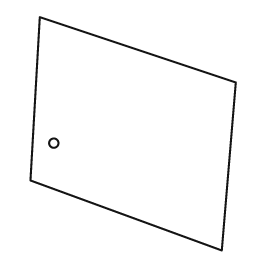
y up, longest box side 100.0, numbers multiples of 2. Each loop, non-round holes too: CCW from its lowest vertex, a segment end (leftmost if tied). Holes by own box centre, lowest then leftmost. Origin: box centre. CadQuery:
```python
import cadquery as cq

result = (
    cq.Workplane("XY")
    .moveTo(38.0, -50.0)
    .lineTo(44.0, 22.0)
    .lineTo(-40.0, 50.0)
    .lineTo(-44.0, -20.0)
    .close()
    .moveTo(-34.0, -4.0)
    .circle(2.0)
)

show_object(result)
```